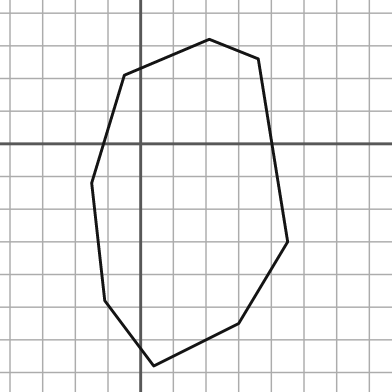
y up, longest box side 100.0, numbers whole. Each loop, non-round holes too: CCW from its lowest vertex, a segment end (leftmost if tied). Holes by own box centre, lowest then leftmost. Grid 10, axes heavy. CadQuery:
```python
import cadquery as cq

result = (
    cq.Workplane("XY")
    .moveTo(4.0, -68.0)
    .lineTo(30.0, -55.0)
    .lineTo(45.0, -30.0)
    .lineTo(36.0, 26.0)
    .lineTo(21.0, 32.0)
    .lineTo(-5.0, 21.0)
    .lineTo(-15.0, -12.0)
    .lineTo(-11.0, -48.0)
    .close()
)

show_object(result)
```